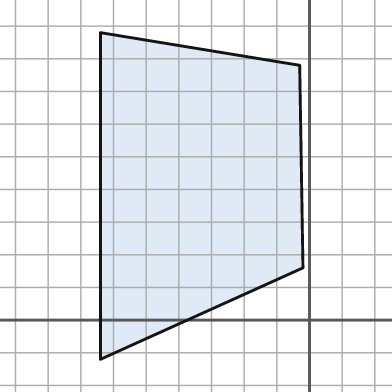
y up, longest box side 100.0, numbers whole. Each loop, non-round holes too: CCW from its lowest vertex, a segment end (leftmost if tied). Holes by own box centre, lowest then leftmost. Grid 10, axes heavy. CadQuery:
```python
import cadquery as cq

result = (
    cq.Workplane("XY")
    .moveTo(-64.0, -12.0)
    .lineTo(-2.0, 16.0)
    .lineTo(-3.0, 78.0)
    .lineTo(-64.0, 88.0)
    .close()
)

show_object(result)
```